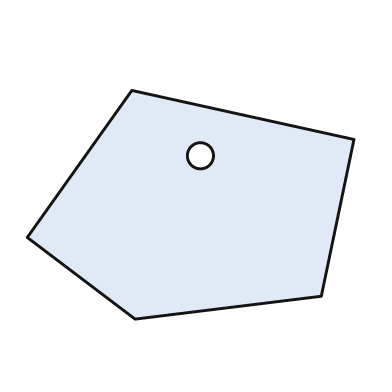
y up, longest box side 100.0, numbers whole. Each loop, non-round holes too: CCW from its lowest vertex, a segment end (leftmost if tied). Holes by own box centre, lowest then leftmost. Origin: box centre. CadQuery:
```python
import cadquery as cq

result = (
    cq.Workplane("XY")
    .moveTo(-17.0, -35.0)
    .lineTo(40.0, -28.0)
    .lineTo(50.0, 20.0)
    .lineTo(-18.0, 35.0)
    .lineTo(-50.0, -10.0)
    .close()
    .moveTo(3.0, 15.0)
    .circle(4.0)
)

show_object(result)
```